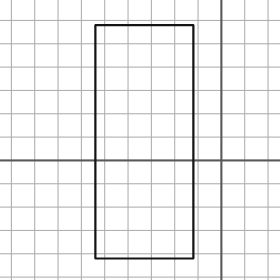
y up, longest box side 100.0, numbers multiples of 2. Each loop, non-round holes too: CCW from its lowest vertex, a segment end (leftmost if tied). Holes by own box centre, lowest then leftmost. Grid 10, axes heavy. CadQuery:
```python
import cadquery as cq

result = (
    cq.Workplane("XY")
    .moveTo(-54.0, -42.0)
    .lineTo(-12.0, -42.0)
    .lineTo(-12.0, 58.0)
    .lineTo(-54.0, 58.0)
    .close()
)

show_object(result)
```